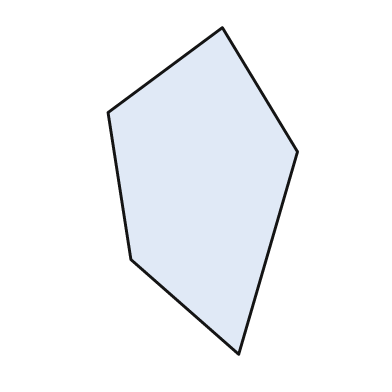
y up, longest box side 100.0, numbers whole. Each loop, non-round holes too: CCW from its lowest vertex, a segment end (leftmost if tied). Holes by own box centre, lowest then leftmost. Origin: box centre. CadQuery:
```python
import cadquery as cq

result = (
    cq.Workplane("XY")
    .moveTo(11.0, -50.0)
    .lineTo(29.0, 12.0)
    .lineTo(6.0, 50.0)
    .lineTo(-29.0, 24.0)
    .lineTo(-22.0, -21.0)
    .close()
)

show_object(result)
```